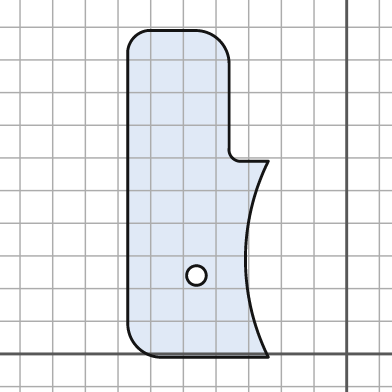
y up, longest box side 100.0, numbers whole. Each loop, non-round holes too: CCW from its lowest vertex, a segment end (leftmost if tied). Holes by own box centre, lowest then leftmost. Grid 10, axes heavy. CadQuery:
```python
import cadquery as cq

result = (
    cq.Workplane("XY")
    .moveTo(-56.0, -1.0)
    .lineTo(-24.0, -1.0)
    .threePointArc((-31.0, 29.0), (-24.0, 59.0))
    .lineTo(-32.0, 59.0)
    .threePointArc((-35.0, 60.0), (-36.0, 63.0))
    .lineTo(-36.0, 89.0)
    .threePointArc((-39.0, 96.0), (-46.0, 99.0))
    .lineTo(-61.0, 99.0)
    .threePointArc((-65.0, 97.0), (-67.0, 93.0))
    .lineTo(-67.0, 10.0)
    .threePointArc((-64.0, 2.0), (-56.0, -1.0))
    .close()
    .moveTo(-46.0, 24.0)
    .circle(3.0)
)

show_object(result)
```